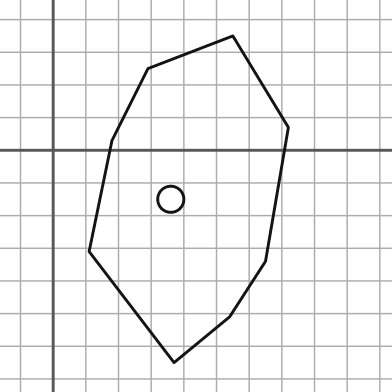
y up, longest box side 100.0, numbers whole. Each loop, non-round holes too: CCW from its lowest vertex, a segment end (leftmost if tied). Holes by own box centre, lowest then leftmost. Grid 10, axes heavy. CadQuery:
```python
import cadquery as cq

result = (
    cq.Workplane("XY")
    .moveTo(37.0, -65.0)
    .lineTo(54.0, -51.0)
    .lineTo(65.0, -34.0)
    .lineTo(72.0, 7.0)
    .lineTo(55.0, 35.0)
    .lineTo(29.0, 25.0)
    .lineTo(18.0, 3.0)
    .lineTo(11.0, -31.0)
    .close()
    .moveTo(36.0, -15.0)
    .circle(4.0)
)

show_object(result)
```